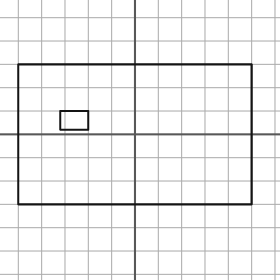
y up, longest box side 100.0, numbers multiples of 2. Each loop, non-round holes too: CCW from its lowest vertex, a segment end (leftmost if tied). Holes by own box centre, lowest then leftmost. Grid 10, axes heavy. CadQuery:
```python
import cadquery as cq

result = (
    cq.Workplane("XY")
    .moveTo(-50.0, -30.0)
    .lineTo(50.0, -30.0)
    .lineTo(50.0, 30.0)
    .lineTo(-50.0, 30.0)
    .close()
    .moveTo(-32.0, 2.0)
    .lineTo(-20.0, 2.0)
    .lineTo(-20.0, 10.0)
    .lineTo(-32.0, 10.0)
    .close()
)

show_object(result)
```